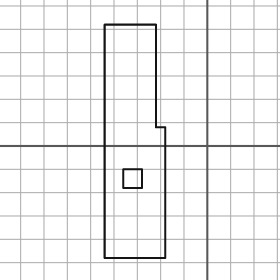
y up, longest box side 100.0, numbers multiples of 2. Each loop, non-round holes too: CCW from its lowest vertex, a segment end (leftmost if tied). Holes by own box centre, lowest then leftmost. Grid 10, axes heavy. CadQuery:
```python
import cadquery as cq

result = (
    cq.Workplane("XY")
    .moveTo(-44.0, -48.0)
    .lineTo(-18.0, -48.0)
    .lineTo(-18.0, 8.0)
    .lineTo(-22.0, 8.0)
    .lineTo(-22.0, 52.0)
    .lineTo(-44.0, 52.0)
    .close()
    .moveTo(-36.0, -18.0)
    .lineTo(-28.0, -18.0)
    .lineTo(-28.0, -10.0)
    .lineTo(-36.0, -10.0)
    .close()
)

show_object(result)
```